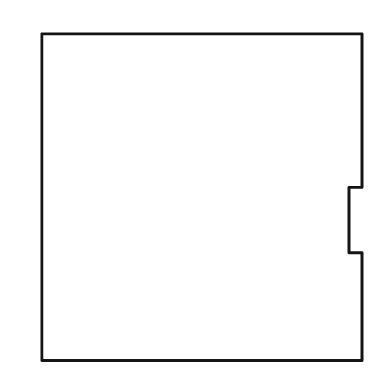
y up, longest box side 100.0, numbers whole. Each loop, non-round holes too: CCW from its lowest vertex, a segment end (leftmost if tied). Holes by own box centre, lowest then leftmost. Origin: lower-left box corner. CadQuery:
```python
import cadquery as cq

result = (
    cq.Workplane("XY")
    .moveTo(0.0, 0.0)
    .lineTo(98.0, 0.0)
    .lineTo(98.0, 33.0)
    .lineTo(94.0, 33.0)
    .lineTo(94.0, 53.0)
    .lineTo(98.0, 53.0)
    .lineTo(98.0, 100.0)
    .lineTo(0.0, 100.0)
    .close()
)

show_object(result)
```